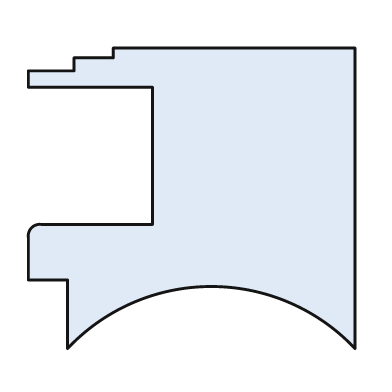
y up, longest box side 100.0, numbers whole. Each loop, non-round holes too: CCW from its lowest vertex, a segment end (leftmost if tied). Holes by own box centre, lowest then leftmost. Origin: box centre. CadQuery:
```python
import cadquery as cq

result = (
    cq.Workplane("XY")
    .moveTo(-38.0, -46.0)
    .threePointArc((6.0, -27.0), (50.0, -46.0))
    .lineTo(50.0, 46.0)
    .lineTo(-24.0, 46.0)
    .lineTo(-24.0, 43.0)
    .lineTo(-36.0, 43.0)
    .lineTo(-36.0, 39.0)
    .lineTo(-50.0, 39.0)
    .lineTo(-50.0, 34.0)
    .lineTo(-12.0, 34.0)
    .lineTo(-12.0, -8.0)
    .lineTo(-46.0, -8.0)
    .threePointArc((-49.0, -9.0), (-50.0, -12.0))
    .lineTo(-50.0, -25.0)
    .lineTo(-38.0, -25.0)
    .close()
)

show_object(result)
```